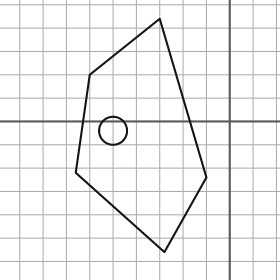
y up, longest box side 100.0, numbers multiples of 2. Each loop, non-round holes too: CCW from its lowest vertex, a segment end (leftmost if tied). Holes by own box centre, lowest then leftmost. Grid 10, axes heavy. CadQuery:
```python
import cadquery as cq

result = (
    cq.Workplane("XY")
    .moveTo(-28.0, -56.0)
    .lineTo(-10.0, -24.0)
    .lineTo(-30.0, 44.0)
    .lineTo(-60.0, 20.0)
    .lineTo(-66.0, -22.0)
    .close()
    .moveTo(-50.0, -4.0)
    .circle(6.0)
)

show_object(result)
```